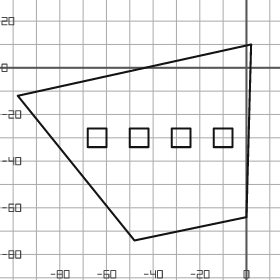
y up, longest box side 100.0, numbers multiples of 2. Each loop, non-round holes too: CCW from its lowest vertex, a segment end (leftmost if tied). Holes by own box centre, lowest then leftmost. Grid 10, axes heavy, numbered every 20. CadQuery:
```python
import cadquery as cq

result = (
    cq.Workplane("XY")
    .moveTo(-48.0, -74.0)
    .lineTo(0.0, -64.0)
    .lineTo(2.0, 10.0)
    .lineTo(-98.0, -12.0)
    .close()
    .moveTo(-68.0, -34.0)
    .lineTo(-60.0, -34.0)
    .lineTo(-60.0, -26.0)
    .lineTo(-68.0, -26.0)
    .close()
    .moveTo(-50.0, -34.0)
    .lineTo(-42.0, -34.0)
    .lineTo(-42.0, -26.0)
    .lineTo(-50.0, -26.0)
    .close()
    .moveTo(-32.0, -34.0)
    .lineTo(-24.0, -34.0)
    .lineTo(-24.0, -26.0)
    .lineTo(-32.0, -26.0)
    .close()
    .moveTo(-14.0, -34.0)
    .lineTo(-6.0, -34.0)
    .lineTo(-6.0, -26.0)
    .lineTo(-14.0, -26.0)
    .close()
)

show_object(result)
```